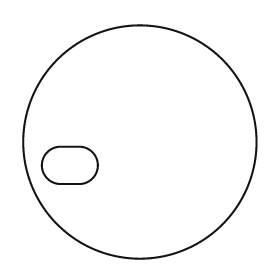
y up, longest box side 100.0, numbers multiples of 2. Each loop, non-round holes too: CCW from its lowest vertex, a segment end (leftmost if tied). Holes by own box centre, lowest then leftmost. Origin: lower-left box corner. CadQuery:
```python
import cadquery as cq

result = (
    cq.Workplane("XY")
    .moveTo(50.0, 50.0)
    .circle(50.0)
    .moveTo(16.0, 32.0)
    .lineTo(24.0, 32.0)
    .threePointArc((32.0, 40.0), (24.0, 48.0))
    .lineTo(16.0, 48.0)
    .threePointArc((8.0, 40.0), (16.0, 32.0))
    .close()
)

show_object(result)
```